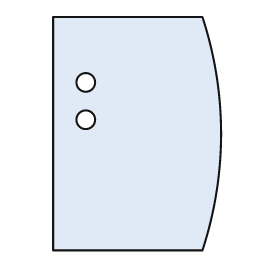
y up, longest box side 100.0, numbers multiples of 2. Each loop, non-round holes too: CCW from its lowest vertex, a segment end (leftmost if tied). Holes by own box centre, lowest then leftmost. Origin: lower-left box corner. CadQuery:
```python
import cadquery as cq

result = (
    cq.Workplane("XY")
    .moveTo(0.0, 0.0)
    .lineTo(64.0, 0.0)
    .threePointArc((72.0, 50.0), (64.0, 100.0))
    .lineTo(0.0, 100.0)
    .close()
    .moveTo(14.0, 56.0)
    .circle(4.0)
    .moveTo(14.0, 72.0)
    .circle(4.0)
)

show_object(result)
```